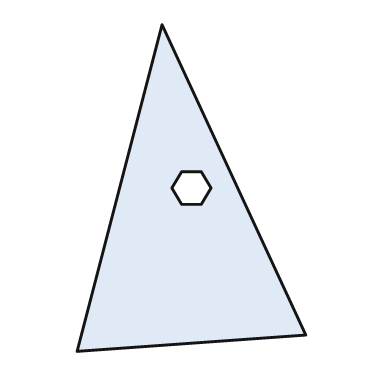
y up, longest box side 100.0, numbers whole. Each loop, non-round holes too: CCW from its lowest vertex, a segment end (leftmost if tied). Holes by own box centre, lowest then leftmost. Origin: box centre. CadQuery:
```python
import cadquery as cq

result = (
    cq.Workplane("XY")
    .moveTo(-35.0, -50.0)
    .lineTo(35.0, -45.0)
    .lineTo(-9.0, 50.0)
    .close()
    .moveTo(-3.0, -5.0)
    .lineTo(3.0, -5.0)
    .lineTo(6.0, 0.0)
    .lineTo(3.0, 5.0)
    .lineTo(-3.0, 5.0)
    .lineTo(-6.0, 0.0)
    .close()
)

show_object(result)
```